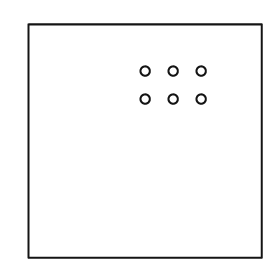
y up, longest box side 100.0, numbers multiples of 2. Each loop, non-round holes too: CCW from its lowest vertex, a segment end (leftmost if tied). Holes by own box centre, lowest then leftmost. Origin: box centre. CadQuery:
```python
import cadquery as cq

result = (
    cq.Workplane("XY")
    .moveTo(-50.0, -50.0)
    .lineTo(50.0, -50.0)
    .lineTo(50.0, 50.0)
    .lineTo(-50.0, 50.0)
    .close()
    .moveTo(0.0, 18.0)
    .circle(2.0)
    .moveTo(12.0, 18.0)
    .circle(2.0)
    .moveTo(24.0, 18.0)
    .circle(2.0)
    .moveTo(0.0, 30.0)
    .circle(2.0)
    .moveTo(12.0, 30.0)
    .circle(2.0)
    .moveTo(24.0, 30.0)
    .circle(2.0)
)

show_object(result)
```